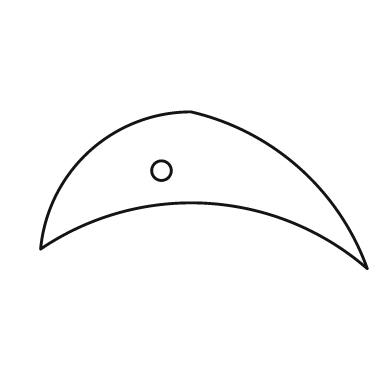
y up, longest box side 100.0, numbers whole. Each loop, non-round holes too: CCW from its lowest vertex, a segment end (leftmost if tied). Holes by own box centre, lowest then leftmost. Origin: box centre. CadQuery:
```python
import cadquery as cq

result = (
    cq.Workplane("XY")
    .moveTo(50.0, -24.0)
    .threePointArc((29.0, 7.0), (-4.0, 24.0))
    .threePointArc((-35.0, 12.0), (-50.0, -18.0))
    .threePointArc((1.0, -4.0), (50.0, -24.0))
    .close()
    .moveTo(-13.0, 6.0)
    .circle(3.0)
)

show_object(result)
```